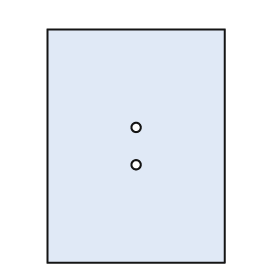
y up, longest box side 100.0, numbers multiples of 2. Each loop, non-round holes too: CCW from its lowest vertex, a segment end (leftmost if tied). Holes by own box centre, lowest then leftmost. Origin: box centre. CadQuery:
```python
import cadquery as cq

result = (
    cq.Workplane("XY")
    .moveTo(-38.0, -50.0)
    .lineTo(38.0, -50.0)
    .lineTo(38.0, 50.0)
    .lineTo(-38.0, 50.0)
    .close()
    .moveTo(0.0, -8.0)
    .circle(2.0)
    .moveTo(0.0, 8.0)
    .circle(2.0)
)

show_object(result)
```